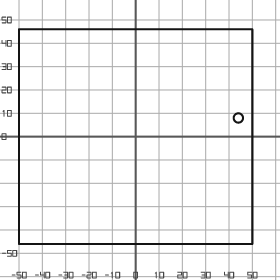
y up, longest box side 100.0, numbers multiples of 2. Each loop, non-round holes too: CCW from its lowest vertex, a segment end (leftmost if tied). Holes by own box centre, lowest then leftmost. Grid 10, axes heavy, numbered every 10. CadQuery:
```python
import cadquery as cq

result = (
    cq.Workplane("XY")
    .moveTo(-50.0, -46.0)
    .lineTo(50.0, -46.0)
    .lineTo(50.0, 46.0)
    .lineTo(-50.0, 46.0)
    .close()
    .moveTo(44.0, 8.0)
    .circle(2.0)
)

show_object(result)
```